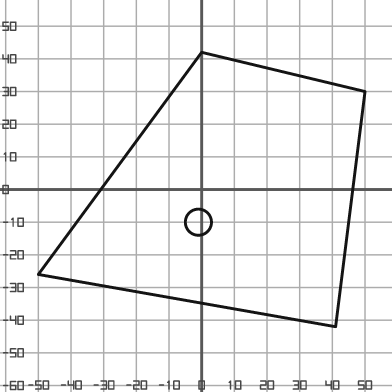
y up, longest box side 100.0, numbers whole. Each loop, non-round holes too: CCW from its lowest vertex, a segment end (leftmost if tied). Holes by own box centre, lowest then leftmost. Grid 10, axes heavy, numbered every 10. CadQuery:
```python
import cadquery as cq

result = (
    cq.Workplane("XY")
    .moveTo(41.0, -42.0)
    .lineTo(50.0, 30.0)
    .lineTo(0.0, 42.0)
    .lineTo(-50.0, -26.0)
    .close()
    .moveTo(-1.0, -10.0)
    .circle(4.0)
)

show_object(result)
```